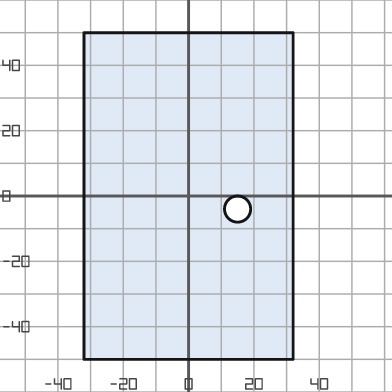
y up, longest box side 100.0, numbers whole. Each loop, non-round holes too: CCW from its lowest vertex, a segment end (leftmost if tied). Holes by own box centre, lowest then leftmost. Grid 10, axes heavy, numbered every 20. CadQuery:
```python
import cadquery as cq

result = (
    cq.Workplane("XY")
    .moveTo(-32.0, -50.0)
    .lineTo(32.0, -50.0)
    .lineTo(32.0, 50.0)
    .lineTo(-32.0, 50.0)
    .close()
    .moveTo(15.0, -4.0)
    .circle(4.0)
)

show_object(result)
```